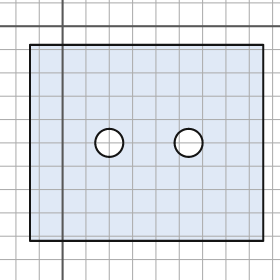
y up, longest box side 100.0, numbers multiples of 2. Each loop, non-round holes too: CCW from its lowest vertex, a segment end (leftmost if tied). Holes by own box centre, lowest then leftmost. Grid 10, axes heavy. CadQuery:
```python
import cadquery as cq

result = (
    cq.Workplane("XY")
    .moveTo(-14.0, -92.0)
    .lineTo(86.0, -92.0)
    .lineTo(86.0, -8.0)
    .lineTo(-14.0, -8.0)
    .close()
    .moveTo(20.0, -50.0)
    .circle(6.0)
    .moveTo(54.0, -50.0)
    .circle(6.0)
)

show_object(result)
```